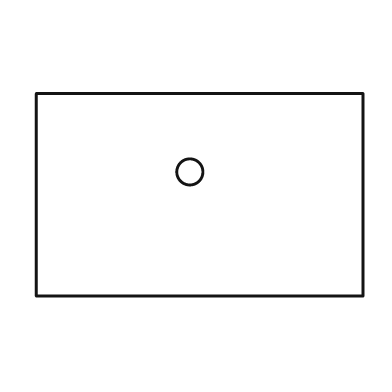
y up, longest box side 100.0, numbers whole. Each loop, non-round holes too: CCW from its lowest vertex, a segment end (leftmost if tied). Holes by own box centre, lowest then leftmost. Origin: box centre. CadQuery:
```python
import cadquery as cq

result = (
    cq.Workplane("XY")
    .moveTo(-50.0, -31.0)
    .lineTo(50.0, -31.0)
    .lineTo(50.0, 31.0)
    .lineTo(-50.0, 31.0)
    .close()
    .moveTo(-3.0, 7.0)
    .circle(4.0)
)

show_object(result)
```